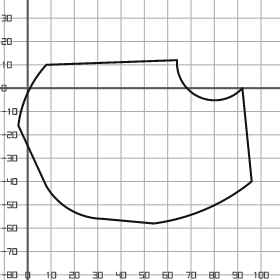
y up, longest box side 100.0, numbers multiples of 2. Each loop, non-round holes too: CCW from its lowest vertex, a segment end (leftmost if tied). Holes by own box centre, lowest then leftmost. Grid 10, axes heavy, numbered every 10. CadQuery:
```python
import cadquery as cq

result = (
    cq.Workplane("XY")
    .moveTo(54.0, -58.0)
    .threePointArc((76.0, -52.0), (96.0, -40.0))
    .lineTo(92.0, 0.0)
    .threePointArc((74.0, -4.0), (64.0, 12.0))
    .lineTo(8.0, 10.0)
    .threePointArc((0.0, -2.0), (-4.0, -16.0))
    .lineTo(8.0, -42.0)
    .threePointArc((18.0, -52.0), (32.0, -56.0))
    .close()
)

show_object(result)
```